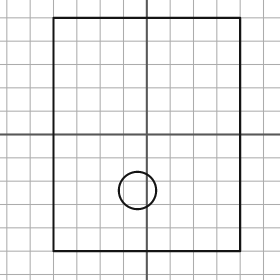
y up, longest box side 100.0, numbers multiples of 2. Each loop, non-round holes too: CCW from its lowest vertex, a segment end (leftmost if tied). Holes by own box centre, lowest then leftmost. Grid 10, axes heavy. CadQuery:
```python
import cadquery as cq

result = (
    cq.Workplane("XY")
    .moveTo(-40.0, -50.0)
    .lineTo(40.0, -50.0)
    .lineTo(40.0, 50.0)
    .lineTo(-40.0, 50.0)
    .close()
    .moveTo(-4.0, -24.0)
    .circle(8.0)
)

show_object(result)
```